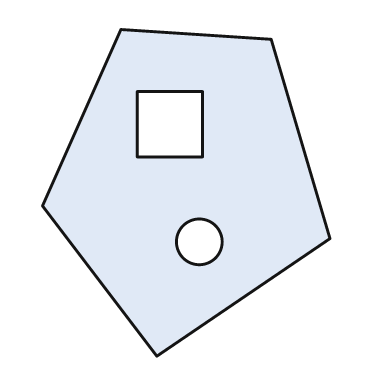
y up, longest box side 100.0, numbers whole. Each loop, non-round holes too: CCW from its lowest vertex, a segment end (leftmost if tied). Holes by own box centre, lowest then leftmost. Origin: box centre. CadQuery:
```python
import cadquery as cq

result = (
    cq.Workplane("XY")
    .moveTo(-9.0, -50.0)
    .lineTo(44.0, -14.0)
    .lineTo(26.0, 47.0)
    .lineTo(-20.0, 50.0)
    .lineTo(-44.0, -4.0)
    .close()
    .moveTo(4.0, -15.0)
    .circle(7.0)
    .moveTo(-15.0, 11.0)
    .lineTo(5.0, 11.0)
    .lineTo(5.0, 31.0)
    .lineTo(-15.0, 31.0)
    .close()
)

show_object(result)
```